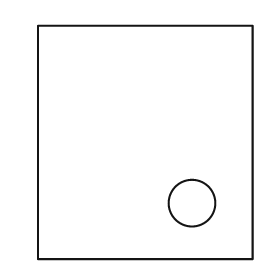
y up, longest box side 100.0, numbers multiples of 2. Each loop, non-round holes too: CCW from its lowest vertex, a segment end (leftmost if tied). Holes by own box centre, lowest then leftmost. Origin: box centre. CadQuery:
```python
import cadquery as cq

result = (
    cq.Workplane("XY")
    .moveTo(-46.0, -50.0)
    .lineTo(46.0, -50.0)
    .lineTo(46.0, 50.0)
    .lineTo(-46.0, 50.0)
    .close()
    .moveTo(20.0, -26.0)
    .circle(10.0)
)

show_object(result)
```